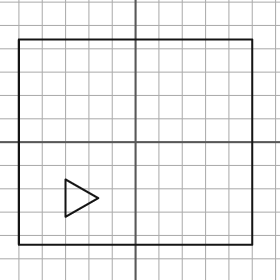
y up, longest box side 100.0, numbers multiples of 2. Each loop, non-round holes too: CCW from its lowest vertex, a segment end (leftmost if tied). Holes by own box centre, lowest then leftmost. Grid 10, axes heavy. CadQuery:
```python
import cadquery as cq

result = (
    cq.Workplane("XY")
    .moveTo(-50.0, -44.0)
    .lineTo(50.0, -44.0)
    .lineTo(50.0, 44.0)
    .lineTo(-50.0, 44.0)
    .close()
    .moveTo(-30.0, -32.0)
    .lineTo(-16.0, -24.0)
    .lineTo(-30.0, -16.0)
    .close()
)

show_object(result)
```